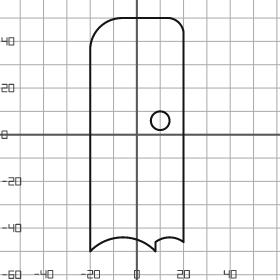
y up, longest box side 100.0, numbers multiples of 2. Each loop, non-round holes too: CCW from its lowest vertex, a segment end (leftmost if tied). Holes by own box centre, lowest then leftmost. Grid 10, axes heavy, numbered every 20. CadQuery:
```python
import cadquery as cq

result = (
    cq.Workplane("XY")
    .moveTo(-20.0, -50.0)
    .threePointArc((-6.0, -44.0), (8.0, -50.0))
    .lineTo(8.0, -46.0)
    .threePointArc((14.0, -44.0), (20.0, -46.0))
    .lineTo(20.0, 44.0)
    .threePointArc((18.0, 48.0), (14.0, 50.0))
    .lineTo(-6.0, 50.0)
    .threePointArc((-16.0, 46.0), (-20.0, 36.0))
    .close()
    .moveTo(10.0, 6.0)
    .circle(4.0)
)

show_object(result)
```